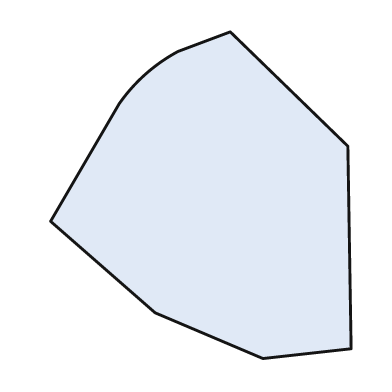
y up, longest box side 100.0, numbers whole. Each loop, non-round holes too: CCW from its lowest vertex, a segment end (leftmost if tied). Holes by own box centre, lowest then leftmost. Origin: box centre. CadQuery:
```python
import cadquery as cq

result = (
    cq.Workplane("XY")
    .moveTo(19.0, -50.0)
    .lineTo(46.0, -47.0)
    .lineTo(45.0, 15.0)
    .lineTo(9.0, 50.0)
    .lineTo(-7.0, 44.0)
    .threePointArc((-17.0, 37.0), (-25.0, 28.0))
    .lineTo(-46.0, -8.0)
    .lineTo(-14.0, -36.0)
    .close()
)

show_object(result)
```